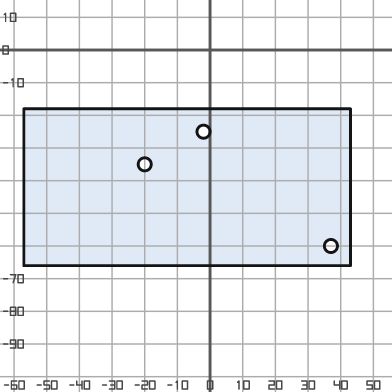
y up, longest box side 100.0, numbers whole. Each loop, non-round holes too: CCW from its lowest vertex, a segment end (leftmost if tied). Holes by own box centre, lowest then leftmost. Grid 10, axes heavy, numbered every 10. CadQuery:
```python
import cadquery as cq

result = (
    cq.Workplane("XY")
    .moveTo(-57.0, -66.0)
    .lineTo(43.0, -66.0)
    .lineTo(43.0, -18.0)
    .lineTo(-57.0, -18.0)
    .close()
    .moveTo(37.0, -60.0)
    .circle(2.0)
    .moveTo(-20.0, -35.0)
    .circle(2.0)
    .moveTo(-2.0, -25.0)
    .circle(2.0)
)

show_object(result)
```